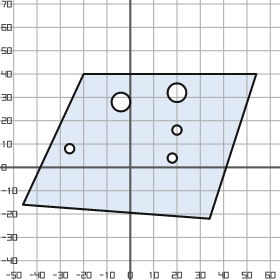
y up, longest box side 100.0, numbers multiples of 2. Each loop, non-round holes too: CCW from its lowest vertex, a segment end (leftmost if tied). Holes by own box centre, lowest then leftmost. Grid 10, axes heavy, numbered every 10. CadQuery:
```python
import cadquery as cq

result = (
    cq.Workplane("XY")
    .moveTo(34.0, -22.0)
    .lineTo(54.0, 40.0)
    .lineTo(-20.0, 40.0)
    .lineTo(-46.0, -16.0)
    .close()
    .moveTo(18.0, 4.0)
    .circle(2.0)
    .moveTo(-26.0, 8.0)
    .circle(2.0)
    .moveTo(20.0, 16.0)
    .circle(2.0)
    .moveTo(-4.0, 28.0)
    .circle(4.0)
    .moveTo(20.0, 32.0)
    .circle(4.0)
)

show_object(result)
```